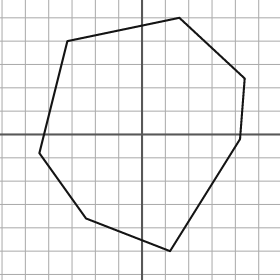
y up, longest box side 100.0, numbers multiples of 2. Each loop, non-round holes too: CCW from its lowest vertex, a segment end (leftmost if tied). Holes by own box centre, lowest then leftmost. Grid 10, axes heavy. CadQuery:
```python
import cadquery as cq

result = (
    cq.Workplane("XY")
    .moveTo(12.0, -50.0)
    .lineTo(42.0, -2.0)
    .lineTo(44.0, 24.0)
    .lineTo(16.0, 50.0)
    .lineTo(-32.0, 40.0)
    .lineTo(-44.0, -8.0)
    .lineTo(-24.0, -36.0)
    .close()
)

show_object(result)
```